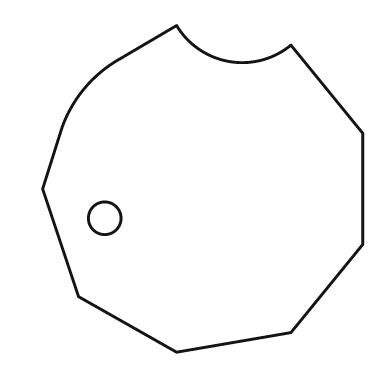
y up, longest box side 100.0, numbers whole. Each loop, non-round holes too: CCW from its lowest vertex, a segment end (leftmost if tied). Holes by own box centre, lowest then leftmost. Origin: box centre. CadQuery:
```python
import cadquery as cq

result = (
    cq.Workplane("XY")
    .moveTo(-8.0, -50.0)
    .lineTo(27.0, -44.0)
    .lineTo(49.0, -17.0)
    .lineTo(49.0, 17.0)
    .lineTo(27.0, 44.0)
    .threePointArc((8.0, 39.0), (-8.0, 50.0))
    .lineTo(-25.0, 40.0)
    .threePointArc((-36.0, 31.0), (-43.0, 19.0))
    .lineTo(-49.0, 0.0)
    .lineTo(-38.0, -33.0)
    .close()
    .moveTo(-30.0, -9.0)
    .circle(5.0)
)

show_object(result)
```